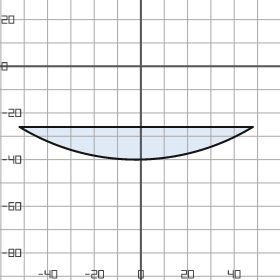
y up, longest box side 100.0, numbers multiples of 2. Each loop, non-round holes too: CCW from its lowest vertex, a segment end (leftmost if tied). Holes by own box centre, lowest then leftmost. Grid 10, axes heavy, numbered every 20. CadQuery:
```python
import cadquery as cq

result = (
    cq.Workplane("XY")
    .moveTo(-52.0, -26.0)
    .threePointArc((-2.0, -40.0), (48.0, -26.0))
    .close()
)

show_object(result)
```